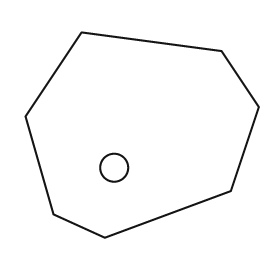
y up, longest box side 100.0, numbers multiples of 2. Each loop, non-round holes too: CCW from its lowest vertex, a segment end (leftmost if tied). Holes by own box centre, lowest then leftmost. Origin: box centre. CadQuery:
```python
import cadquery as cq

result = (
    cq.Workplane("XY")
    .moveTo(-16.0, -44.0)
    .lineTo(38.0, -24.0)
    .lineTo(50.0, 12.0)
    .lineTo(34.0, 36.0)
    .lineTo(-26.0, 44.0)
    .lineTo(-50.0, 8.0)
    .lineTo(-38.0, -34.0)
    .close()
    .moveTo(-12.0, -14.0)
    .circle(6.0)
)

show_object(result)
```